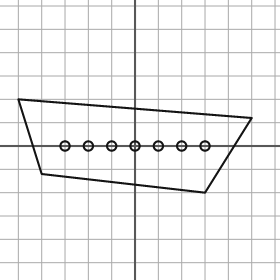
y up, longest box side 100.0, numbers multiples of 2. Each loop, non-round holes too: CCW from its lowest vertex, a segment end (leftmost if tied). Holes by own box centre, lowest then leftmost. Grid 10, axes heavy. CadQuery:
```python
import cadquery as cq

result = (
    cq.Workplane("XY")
    .moveTo(30.0, -20.0)
    .lineTo(50.0, 12.0)
    .lineTo(-50.0, 20.0)
    .lineTo(-40.0, -12.0)
    .close()
    .moveTo(-30.0, 0.0)
    .circle(2.0)
    .moveTo(-20.0, 0.0)
    .circle(2.0)
    .moveTo(-10.0, 0.0)
    .circle(2.0)
    .moveTo(0.0, 0.0)
    .circle(2.0)
    .moveTo(10.0, 0.0)
    .circle(2.0)
    .moveTo(20.0, 0.0)
    .circle(2.0)
    .moveTo(30.0, 0.0)
    .circle(2.0)
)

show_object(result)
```